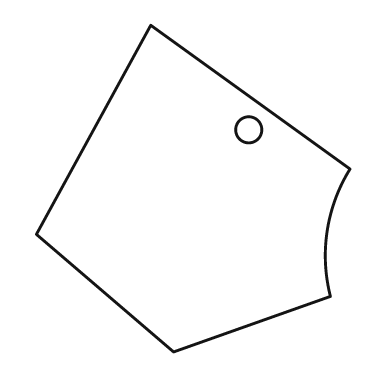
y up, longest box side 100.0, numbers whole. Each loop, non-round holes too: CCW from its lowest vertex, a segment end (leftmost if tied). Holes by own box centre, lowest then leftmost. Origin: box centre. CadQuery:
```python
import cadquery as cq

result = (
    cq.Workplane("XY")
    .moveTo(-6.0, -50.0)
    .lineTo(42.0, -33.0)
    .threePointArc((41.0, -13.0), (48.0, 6.0))
    .lineTo(-13.0, 50.0)
    .lineTo(-48.0, -14.0)
    .close()
    .moveTo(17.0, 18.0)
    .circle(4.0)
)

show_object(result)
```